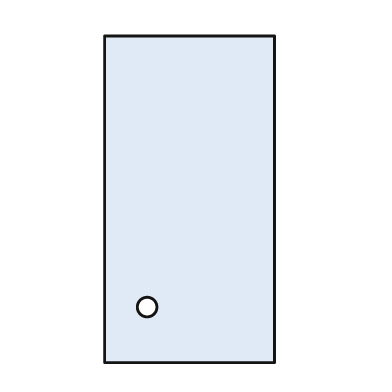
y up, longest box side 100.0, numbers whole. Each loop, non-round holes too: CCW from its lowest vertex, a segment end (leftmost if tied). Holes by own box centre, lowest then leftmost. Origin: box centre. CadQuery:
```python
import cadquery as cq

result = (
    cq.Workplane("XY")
    .moveTo(-26.0, -50.0)
    .lineTo(26.0, -50.0)
    .lineTo(26.0, 50.0)
    .lineTo(-26.0, 50.0)
    .close()
    .moveTo(-13.0, -33.0)
    .circle(3.0)
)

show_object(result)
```